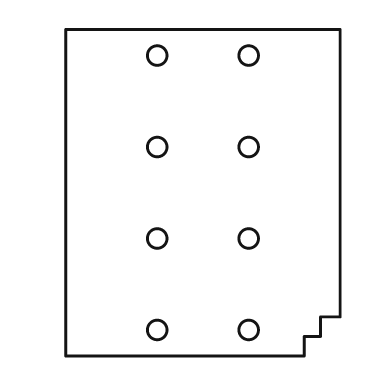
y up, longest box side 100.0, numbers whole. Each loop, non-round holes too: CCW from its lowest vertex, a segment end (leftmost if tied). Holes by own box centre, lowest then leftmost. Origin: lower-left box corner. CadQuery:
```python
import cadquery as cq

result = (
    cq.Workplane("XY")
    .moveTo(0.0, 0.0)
    .lineTo(73.0, 0.0)
    .lineTo(73.0, 6.0)
    .lineTo(78.0, 6.0)
    .lineTo(78.0, 12.0)
    .lineTo(84.0, 12.0)
    .lineTo(84.0, 100.0)
    .lineTo(0.0, 100.0)
    .close()
    .moveTo(28.0, 8.0)
    .circle(3.0)
    .moveTo(56.0, 8.0)
    .circle(3.0)
    .moveTo(28.0, 36.0)
    .circle(3.0)
    .moveTo(56.0, 36.0)
    .circle(3.0)
    .moveTo(28.0, 64.0)
    .circle(3.0)
    .moveTo(56.0, 64.0)
    .circle(3.0)
    .moveTo(28.0, 92.0)
    .circle(3.0)
    .moveTo(56.0, 92.0)
    .circle(3.0)
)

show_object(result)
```